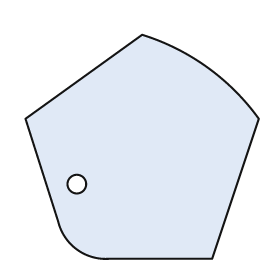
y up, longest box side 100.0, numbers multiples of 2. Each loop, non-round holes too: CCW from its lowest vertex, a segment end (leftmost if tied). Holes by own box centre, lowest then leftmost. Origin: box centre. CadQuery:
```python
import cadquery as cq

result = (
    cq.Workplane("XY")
    .moveTo(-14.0, -48.0)
    .lineTo(30.0, -48.0)
    .lineTo(50.0, 12.0)
    .threePointArc((28.0, 34.0), (0.0, 48.0))
    .lineTo(-50.0, 12.0)
    .lineTo(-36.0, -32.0)
    .threePointArc((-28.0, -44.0), (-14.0, -48.0))
    .close()
    .moveTo(-28.0, -16.0)
    .circle(4.0)
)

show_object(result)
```